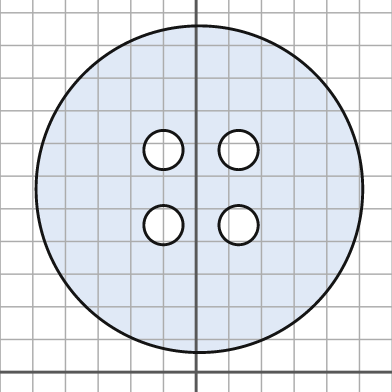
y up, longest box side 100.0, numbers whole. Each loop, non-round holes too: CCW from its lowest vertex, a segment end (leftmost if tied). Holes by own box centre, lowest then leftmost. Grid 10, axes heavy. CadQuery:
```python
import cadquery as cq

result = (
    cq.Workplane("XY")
    .moveTo(1.0, 56.0)
    .circle(50.0)
    .moveTo(-10.0, 45.0)
    .circle(6.0)
    .moveTo(13.0, 45.0)
    .circle(6.0)
    .moveTo(-10.0, 68.0)
    .circle(6.0)
    .moveTo(13.0, 68.0)
    .circle(6.0)
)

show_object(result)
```